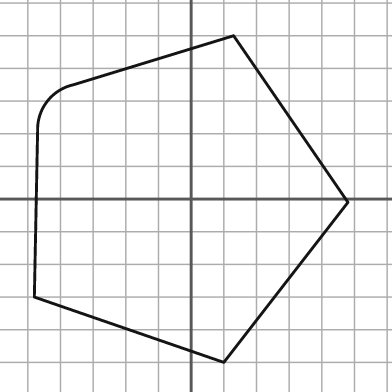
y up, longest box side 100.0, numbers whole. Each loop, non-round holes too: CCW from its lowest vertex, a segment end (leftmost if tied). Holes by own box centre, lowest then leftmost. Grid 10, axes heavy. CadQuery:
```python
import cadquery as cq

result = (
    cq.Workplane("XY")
    .moveTo(10.0, -50.0)
    .lineTo(48.0, -1.0)
    .lineTo(13.0, 50.0)
    .lineTo(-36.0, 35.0)
    .threePointArc((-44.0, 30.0), (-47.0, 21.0))
    .lineTo(-48.0, -30.0)
    .close()
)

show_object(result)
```